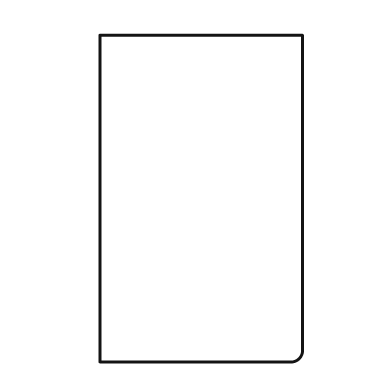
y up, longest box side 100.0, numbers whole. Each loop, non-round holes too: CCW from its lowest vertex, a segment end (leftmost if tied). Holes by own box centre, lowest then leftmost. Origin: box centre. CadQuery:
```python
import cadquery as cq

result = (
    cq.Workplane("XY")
    .moveTo(-31.0, -50.0)
    .lineTo(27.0, -50.0)
    .threePointArc((30.0, -49.0), (31.0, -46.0))
    .lineTo(31.0, 50.0)
    .lineTo(-31.0, 50.0)
    .close()
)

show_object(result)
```